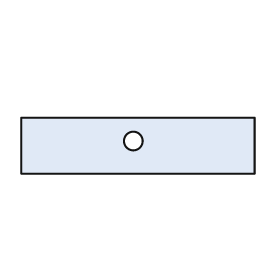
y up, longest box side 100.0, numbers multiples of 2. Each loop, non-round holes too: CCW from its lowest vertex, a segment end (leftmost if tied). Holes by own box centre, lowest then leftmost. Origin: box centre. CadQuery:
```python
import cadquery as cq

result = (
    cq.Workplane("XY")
    .moveTo(-50.0, -12.0)
    .lineTo(50.0, -12.0)
    .lineTo(50.0, 12.0)
    .lineTo(-50.0, 12.0)
    .close()
    .moveTo(-2.0, 2.0)
    .circle(4.0)
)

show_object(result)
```